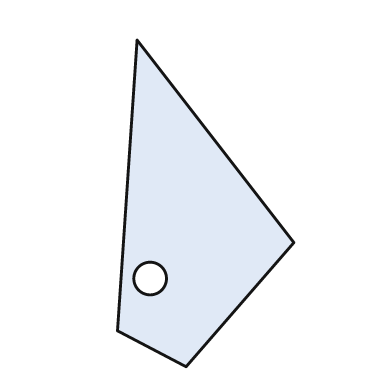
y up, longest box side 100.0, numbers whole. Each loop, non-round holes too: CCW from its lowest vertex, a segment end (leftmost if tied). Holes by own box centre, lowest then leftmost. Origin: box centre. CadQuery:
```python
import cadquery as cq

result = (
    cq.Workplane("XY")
    .moveTo(-6.0, -50.0)
    .lineTo(27.0, -12.0)
    .lineTo(-21.0, 50.0)
    .lineTo(-27.0, -39.0)
    .close()
    .moveTo(-17.0, -23.0)
    .circle(5.0)
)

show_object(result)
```